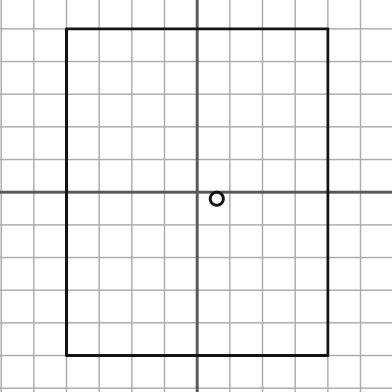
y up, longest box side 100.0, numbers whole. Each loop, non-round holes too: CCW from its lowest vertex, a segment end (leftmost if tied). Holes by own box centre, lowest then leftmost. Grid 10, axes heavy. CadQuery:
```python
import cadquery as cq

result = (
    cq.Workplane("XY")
    .moveTo(-40.0, -50.0)
    .lineTo(40.0, -50.0)
    .lineTo(40.0, 50.0)
    .lineTo(-40.0, 50.0)
    .close()
    .moveTo(6.0, -2.0)
    .circle(2.0)
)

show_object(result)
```